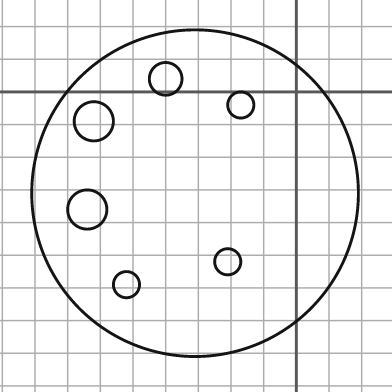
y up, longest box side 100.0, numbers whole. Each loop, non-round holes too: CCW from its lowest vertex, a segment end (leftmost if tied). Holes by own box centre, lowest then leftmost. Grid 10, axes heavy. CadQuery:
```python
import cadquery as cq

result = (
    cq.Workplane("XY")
    .moveTo(-31.0, -31.0)
    .circle(50.0)
    .moveTo(-52.0, -59.0)
    .circle(4.0)
    .moveTo(-21.0, -52.0)
    .circle(4.0)
    .moveTo(-64.0, -36.0)
    .circle(6.0)
    .moveTo(-62.0, -9.0)
    .circle(6.0)
    .moveTo(-17.0, -4.0)
    .circle(4.0)
    .moveTo(-40.0, 4.0)
    .circle(5.0)
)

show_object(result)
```